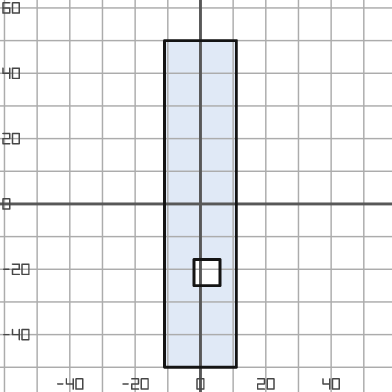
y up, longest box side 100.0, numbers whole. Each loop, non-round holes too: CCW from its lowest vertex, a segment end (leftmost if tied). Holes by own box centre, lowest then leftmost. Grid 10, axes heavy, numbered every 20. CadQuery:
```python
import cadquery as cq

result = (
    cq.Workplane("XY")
    .moveTo(-11.0, -50.0)
    .lineTo(11.0, -50.0)
    .lineTo(11.0, 50.0)
    .lineTo(-11.0, 50.0)
    .close()
    .moveTo(-2.0, -25.0)
    .lineTo(6.0, -25.0)
    .lineTo(6.0, -17.0)
    .lineTo(-2.0, -17.0)
    .close()
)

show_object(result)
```